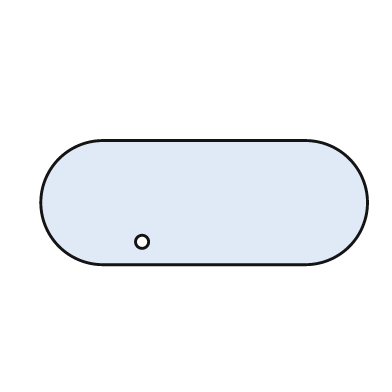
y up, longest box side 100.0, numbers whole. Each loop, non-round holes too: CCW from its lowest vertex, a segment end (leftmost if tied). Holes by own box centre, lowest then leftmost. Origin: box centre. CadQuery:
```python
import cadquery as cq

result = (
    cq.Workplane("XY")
    .moveTo(-31.0, -19.0)
    .lineTo(31.0, -19.0)
    .threePointArc((50.0, 0.0), (31.0, 19.0))
    .lineTo(-31.0, 19.0)
    .threePointArc((-50.0, 0.0), (-31.0, -19.0))
    .close()
    .moveTo(-19.0, -12.0)
    .circle(2.0)
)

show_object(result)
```